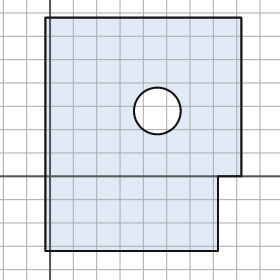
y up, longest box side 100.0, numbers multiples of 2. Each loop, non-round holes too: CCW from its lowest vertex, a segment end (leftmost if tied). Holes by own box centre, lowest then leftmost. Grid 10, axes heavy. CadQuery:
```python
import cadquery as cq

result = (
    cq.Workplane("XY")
    .moveTo(-2.0, -32.0)
    .lineTo(72.0, -32.0)
    .lineTo(72.0, 0.0)
    .lineTo(82.0, 0.0)
    .lineTo(82.0, 68.0)
    .lineTo(-2.0, 68.0)
    .close()
    .moveTo(46.0, 28.0)
    .circle(10.0)
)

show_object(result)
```